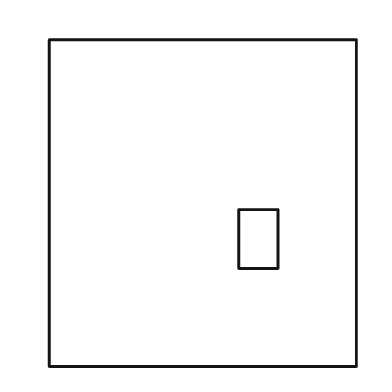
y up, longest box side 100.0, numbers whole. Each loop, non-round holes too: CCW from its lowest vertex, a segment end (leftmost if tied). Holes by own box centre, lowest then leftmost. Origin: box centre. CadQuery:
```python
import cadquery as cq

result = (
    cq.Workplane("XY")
    .moveTo(-47.0, -50.0)
    .lineTo(47.0, -50.0)
    .lineTo(47.0, 50.0)
    .lineTo(-47.0, 50.0)
    .close()
    .moveTo(11.0, -20.0)
    .lineTo(23.0, -20.0)
    .lineTo(23.0, -2.0)
    .lineTo(11.0, -2.0)
    .close()
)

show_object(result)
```